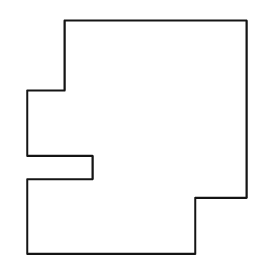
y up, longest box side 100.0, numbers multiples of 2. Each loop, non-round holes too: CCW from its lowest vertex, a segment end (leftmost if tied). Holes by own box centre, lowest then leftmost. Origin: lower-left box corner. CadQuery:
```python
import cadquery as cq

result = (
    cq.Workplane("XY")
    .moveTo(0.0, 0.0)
    .lineTo(72.0, 0.0)
    .lineTo(72.0, 24.0)
    .lineTo(94.0, 24.0)
    .lineTo(94.0, 100.0)
    .lineTo(16.0, 100.0)
    .lineTo(16.0, 70.0)
    .lineTo(0.0, 70.0)
    .lineTo(0.0, 42.0)
    .lineTo(28.0, 42.0)
    .lineTo(28.0, 32.0)
    .lineTo(0.0, 32.0)
    .close()
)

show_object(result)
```